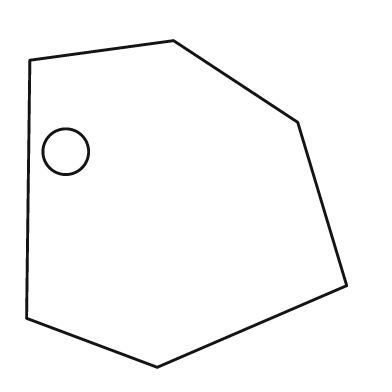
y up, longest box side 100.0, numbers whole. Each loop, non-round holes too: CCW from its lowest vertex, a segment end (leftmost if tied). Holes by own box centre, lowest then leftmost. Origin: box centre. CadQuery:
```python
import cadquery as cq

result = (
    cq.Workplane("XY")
    .moveTo(-9.0, -50.0)
    .lineTo(49.0, -25.0)
    .lineTo(34.0, 25.0)
    .lineTo(-4.0, 50.0)
    .lineTo(-48.0, 44.0)
    .lineTo(-49.0, -35.0)
    .close()
    .moveTo(-37.0, 16.0)
    .circle(7.0)
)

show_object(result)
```